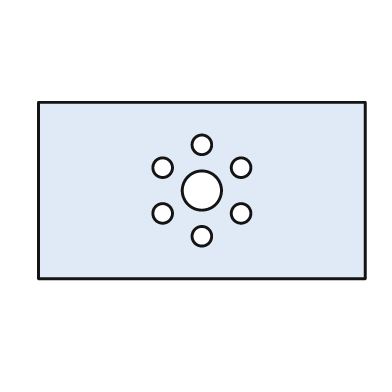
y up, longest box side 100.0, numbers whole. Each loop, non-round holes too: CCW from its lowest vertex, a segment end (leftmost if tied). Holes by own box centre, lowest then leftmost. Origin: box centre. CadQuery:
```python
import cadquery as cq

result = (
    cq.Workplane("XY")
    .moveTo(-50.0, -27.0)
    .lineTo(50.0, -27.0)
    .lineTo(50.0, 27.0)
    .lineTo(-50.0, 27.0)
    .close()
    .moveTo(0.0, -14.0)
    .circle(3.0)
    .moveTo(-12.0, -7.0)
    .circle(3.0)
    .moveTo(12.0, -7.0)
    .circle(3.0)
    .moveTo(0.0, 0.0)
    .circle(6.0)
    .moveTo(-12.0, 7.0)
    .circle(3.0)
    .moveTo(12.0, 7.0)
    .circle(3.0)
    .moveTo(0.0, 14.0)
    .circle(3.0)
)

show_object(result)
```